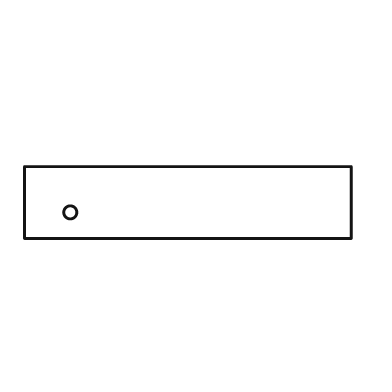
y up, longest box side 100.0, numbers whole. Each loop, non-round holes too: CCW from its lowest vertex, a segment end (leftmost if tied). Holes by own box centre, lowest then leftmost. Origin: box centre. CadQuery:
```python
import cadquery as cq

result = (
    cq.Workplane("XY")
    .moveTo(-50.0, -11.0)
    .lineTo(50.0, -11.0)
    .lineTo(50.0, 11.0)
    .lineTo(-50.0, 11.0)
    .close()
    .moveTo(-36.0, -3.0)
    .circle(2.0)
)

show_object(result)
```